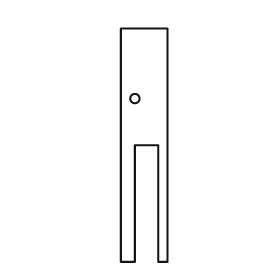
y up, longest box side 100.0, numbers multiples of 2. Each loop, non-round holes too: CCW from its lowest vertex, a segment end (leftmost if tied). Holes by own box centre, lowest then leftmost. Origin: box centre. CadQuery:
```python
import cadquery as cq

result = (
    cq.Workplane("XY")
    .moveTo(-10.0, -50.0)
    .lineTo(-4.0, -50.0)
    .lineTo(-4.0, 0.0)
    .lineTo(6.0, 0.0)
    .lineTo(6.0, -50.0)
    .lineTo(10.0, -50.0)
    .lineTo(10.0, 50.0)
    .lineTo(-10.0, 50.0)
    .close()
    .moveTo(-4.0, 20.0)
    .circle(2.0)
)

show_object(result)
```